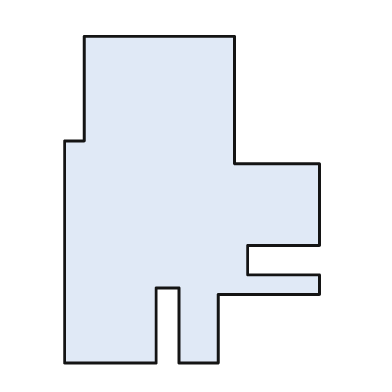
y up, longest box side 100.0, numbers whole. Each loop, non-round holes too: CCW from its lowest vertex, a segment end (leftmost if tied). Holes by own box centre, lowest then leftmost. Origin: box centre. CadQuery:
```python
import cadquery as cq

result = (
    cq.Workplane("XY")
    .moveTo(-39.0, -50.0)
    .lineTo(-11.0, -50.0)
    .lineTo(-11.0, -27.0)
    .lineTo(-4.0, -27.0)
    .lineTo(-4.0, -50.0)
    .lineTo(8.0, -50.0)
    .lineTo(8.0, -29.0)
    .lineTo(39.0, -29.0)
    .lineTo(39.0, -23.0)
    .lineTo(17.0, -23.0)
    .lineTo(17.0, -14.0)
    .lineTo(39.0, -14.0)
    .lineTo(39.0, 11.0)
    .lineTo(13.0, 11.0)
    .lineTo(13.0, 50.0)
    .lineTo(-33.0, 50.0)
    .lineTo(-33.0, 18.0)
    .lineTo(-39.0, 18.0)
    .close()
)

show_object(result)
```